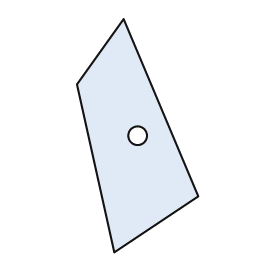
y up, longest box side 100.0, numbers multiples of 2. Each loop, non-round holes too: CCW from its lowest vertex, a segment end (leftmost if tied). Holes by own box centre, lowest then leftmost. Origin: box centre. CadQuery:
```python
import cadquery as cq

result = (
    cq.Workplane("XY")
    .moveTo(-10.0, -50.0)
    .lineTo(26.0, -26.0)
    .lineTo(-6.0, 50.0)
    .lineTo(-26.0, 22.0)
    .close()
    .moveTo(0.0, 0.0)
    .circle(4.0)
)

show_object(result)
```